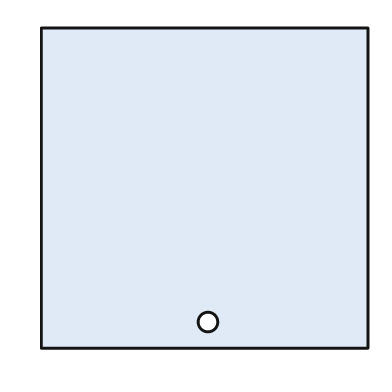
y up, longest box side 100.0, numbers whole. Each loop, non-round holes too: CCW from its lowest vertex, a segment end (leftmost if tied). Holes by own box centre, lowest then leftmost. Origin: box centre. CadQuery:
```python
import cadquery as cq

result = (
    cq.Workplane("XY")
    .moveTo(-50.0, -49.0)
    .lineTo(50.0, -49.0)
    .lineTo(50.0, 49.0)
    .lineTo(-50.0, 49.0)
    .close()
    .moveTo(1.0, -41.0)
    .circle(3.0)
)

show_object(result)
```